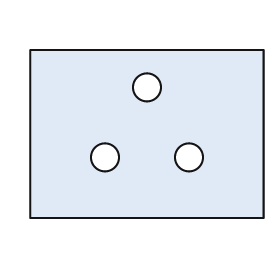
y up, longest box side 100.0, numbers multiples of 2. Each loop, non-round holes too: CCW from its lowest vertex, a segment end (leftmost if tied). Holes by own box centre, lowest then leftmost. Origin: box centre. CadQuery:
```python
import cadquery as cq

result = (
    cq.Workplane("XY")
    .moveTo(-50.0, -36.0)
    .lineTo(50.0, -36.0)
    .lineTo(50.0, 36.0)
    .lineTo(-50.0, 36.0)
    .close()
    .moveTo(-18.0, -10.0)
    .circle(6.0)
    .moveTo(18.0, -10.0)
    .circle(6.0)
    .moveTo(0.0, 20.0)
    .circle(6.0)
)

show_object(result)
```